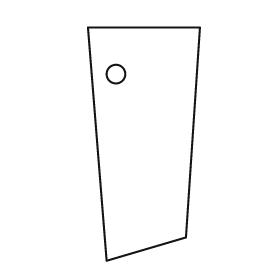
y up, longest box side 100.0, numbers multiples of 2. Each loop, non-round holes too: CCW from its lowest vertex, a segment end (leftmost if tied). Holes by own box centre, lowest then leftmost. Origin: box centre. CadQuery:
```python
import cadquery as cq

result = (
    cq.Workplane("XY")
    .moveTo(-16.0, -50.0)
    .lineTo(18.0, -40.0)
    .lineTo(24.0, 50.0)
    .lineTo(-24.0, 50.0)
    .close()
    .moveTo(-12.0, 30.0)
    .circle(4.0)
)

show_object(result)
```